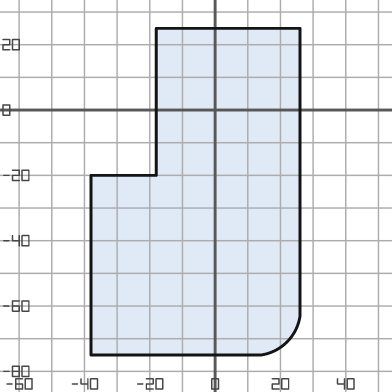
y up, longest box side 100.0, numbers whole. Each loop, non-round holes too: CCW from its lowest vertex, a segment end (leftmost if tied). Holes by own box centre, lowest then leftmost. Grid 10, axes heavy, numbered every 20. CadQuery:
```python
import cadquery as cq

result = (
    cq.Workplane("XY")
    .moveTo(-38.0, -75.0)
    .lineTo(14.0, -75.0)
    .threePointArc((22.0, -71.0), (26.0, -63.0))
    .lineTo(26.0, 25.0)
    .lineTo(-18.0, 25.0)
    .lineTo(-18.0, -20.0)
    .lineTo(-38.0, -20.0)
    .close()
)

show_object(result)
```